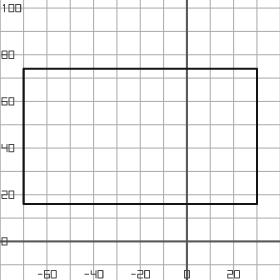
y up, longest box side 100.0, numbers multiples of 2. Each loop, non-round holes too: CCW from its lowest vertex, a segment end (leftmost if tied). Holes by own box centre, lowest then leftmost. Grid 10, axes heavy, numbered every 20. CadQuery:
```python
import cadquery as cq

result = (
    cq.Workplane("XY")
    .moveTo(-70.0, 16.0)
    .lineTo(30.0, 16.0)
    .lineTo(30.0, 74.0)
    .lineTo(-70.0, 74.0)
    .close()
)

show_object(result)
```